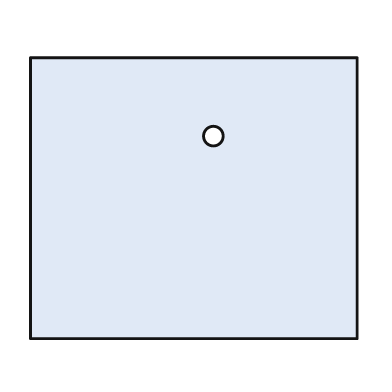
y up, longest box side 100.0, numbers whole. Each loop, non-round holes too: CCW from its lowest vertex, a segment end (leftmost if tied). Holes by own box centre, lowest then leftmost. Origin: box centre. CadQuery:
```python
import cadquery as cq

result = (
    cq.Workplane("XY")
    .moveTo(-50.0, -43.0)
    .lineTo(50.0, -43.0)
    .lineTo(50.0, 43.0)
    .lineTo(-50.0, 43.0)
    .close()
    .moveTo(6.0, 19.0)
    .circle(3.0)
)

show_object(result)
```